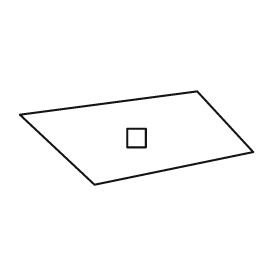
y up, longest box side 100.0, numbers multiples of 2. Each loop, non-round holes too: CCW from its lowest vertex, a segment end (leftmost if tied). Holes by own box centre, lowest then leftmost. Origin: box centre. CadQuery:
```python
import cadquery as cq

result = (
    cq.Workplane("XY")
    .moveTo(-18.0, -20.0)
    .lineTo(50.0, -6.0)
    .lineTo(26.0, 20.0)
    .lineTo(-50.0, 10.0)
    .close()
    .moveTo(-4.0, -4.0)
    .lineTo(4.0, -4.0)
    .lineTo(4.0, 4.0)
    .lineTo(-4.0, 4.0)
    .close()
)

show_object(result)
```